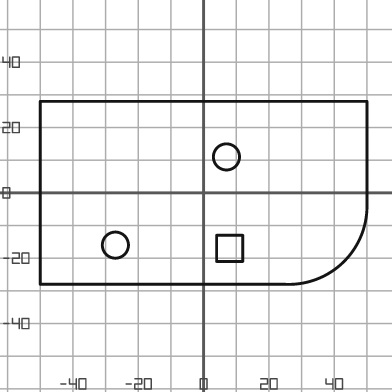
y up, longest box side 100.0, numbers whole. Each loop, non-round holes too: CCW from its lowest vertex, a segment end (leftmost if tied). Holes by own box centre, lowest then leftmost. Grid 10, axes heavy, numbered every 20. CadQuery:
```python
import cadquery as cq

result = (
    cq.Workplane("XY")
    .moveTo(-50.0, -28.0)
    .lineTo(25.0, -28.0)
    .threePointArc((43.0, -21.0), (50.0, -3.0))
    .lineTo(50.0, 28.0)
    .lineTo(-50.0, 28.0)
    .close()
    .moveTo(4.0, -21.0)
    .lineTo(12.0, -21.0)
    .lineTo(12.0, -13.0)
    .lineTo(4.0, -13.0)
    .close()
    .moveTo(-27.0, -16.0)
    .circle(4.0)
    .moveTo(7.0, 11.0)
    .circle(4.0)
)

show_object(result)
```